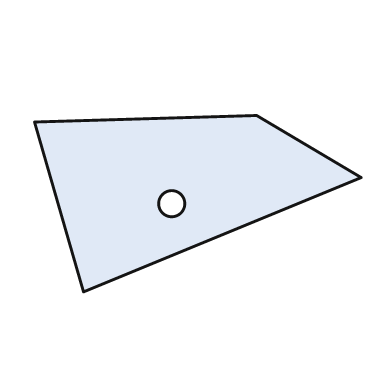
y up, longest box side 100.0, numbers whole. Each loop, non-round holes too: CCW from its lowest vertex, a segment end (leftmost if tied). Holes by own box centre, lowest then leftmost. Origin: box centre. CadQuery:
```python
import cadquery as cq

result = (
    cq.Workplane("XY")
    .moveTo(-35.0, -27.0)
    .lineTo(50.0, 8.0)
    .lineTo(18.0, 27.0)
    .lineTo(-50.0, 25.0)
    .close()
    .moveTo(-8.0, 0.0)
    .circle(4.0)
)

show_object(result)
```